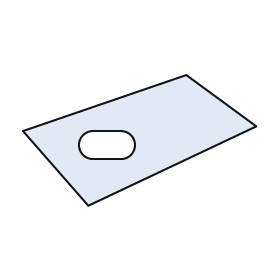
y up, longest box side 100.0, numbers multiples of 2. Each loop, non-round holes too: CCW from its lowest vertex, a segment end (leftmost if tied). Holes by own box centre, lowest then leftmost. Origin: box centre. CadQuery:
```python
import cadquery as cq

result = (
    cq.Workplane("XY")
    .moveTo(-22.0, -28.0)
    .lineTo(50.0, 6.0)
    .lineTo(20.0, 28.0)
    .lineTo(-50.0, 4.0)
    .close()
    .moveTo(-20.0, -8.0)
    .lineTo(-8.0, -8.0)
    .threePointArc((-2.0, -2.0), (-8.0, 4.0))
    .lineTo(-20.0, 4.0)
    .threePointArc((-26.0, -2.0), (-20.0, -8.0))
    .close()
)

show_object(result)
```